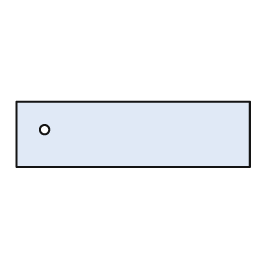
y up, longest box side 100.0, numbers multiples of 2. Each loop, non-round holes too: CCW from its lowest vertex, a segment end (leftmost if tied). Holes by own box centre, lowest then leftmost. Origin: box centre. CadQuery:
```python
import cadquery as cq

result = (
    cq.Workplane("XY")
    .moveTo(-50.0, -14.0)
    .lineTo(50.0, -14.0)
    .lineTo(50.0, 14.0)
    .lineTo(-50.0, 14.0)
    .close()
    .moveTo(-38.0, 2.0)
    .circle(2.0)
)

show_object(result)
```